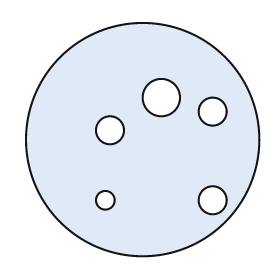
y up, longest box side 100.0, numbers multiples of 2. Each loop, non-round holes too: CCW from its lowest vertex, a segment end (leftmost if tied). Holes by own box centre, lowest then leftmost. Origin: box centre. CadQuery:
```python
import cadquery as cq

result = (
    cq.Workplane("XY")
    .moveTo(0.0, 0.0)
    .circle(50.0)
    .moveTo(-16.0, -26.0)
    .circle(4.0)
    .moveTo(30.0, -26.0)
    .circle(6.0)
    .moveTo(-14.0, 4.0)
    .circle(6.0)
    .moveTo(30.0, 12.0)
    .circle(6.0)
    .moveTo(8.0, 18.0)
    .circle(8.0)
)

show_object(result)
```